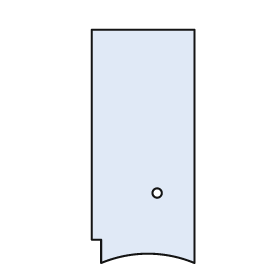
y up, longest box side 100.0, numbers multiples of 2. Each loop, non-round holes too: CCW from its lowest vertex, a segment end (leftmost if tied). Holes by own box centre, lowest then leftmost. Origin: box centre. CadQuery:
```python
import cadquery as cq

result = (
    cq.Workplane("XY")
    .moveTo(-18.0, -50.0)
    .threePointArc((2.0, -46.0), (22.0, -50.0))
    .lineTo(22.0, 50.0)
    .lineTo(-22.0, 50.0)
    .lineTo(-22.0, -40.0)
    .lineTo(-18.0, -40.0)
    .close()
    .moveTo(6.0, -20.0)
    .circle(2.0)
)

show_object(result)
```